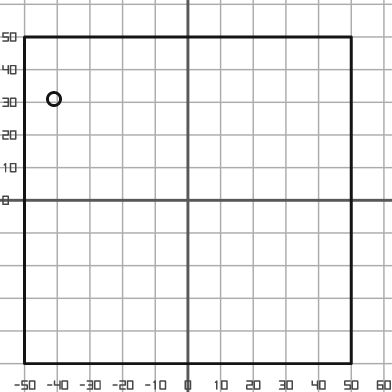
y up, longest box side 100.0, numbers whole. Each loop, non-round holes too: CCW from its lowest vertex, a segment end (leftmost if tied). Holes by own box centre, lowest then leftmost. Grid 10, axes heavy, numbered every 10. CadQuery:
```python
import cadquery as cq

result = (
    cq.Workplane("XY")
    .moveTo(-50.0, -50.0)
    .lineTo(50.0, -50.0)
    .lineTo(50.0, 50.0)
    .lineTo(-50.0, 50.0)
    .close()
    .moveTo(-41.0, 31.0)
    .circle(2.0)
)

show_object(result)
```